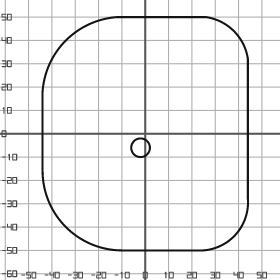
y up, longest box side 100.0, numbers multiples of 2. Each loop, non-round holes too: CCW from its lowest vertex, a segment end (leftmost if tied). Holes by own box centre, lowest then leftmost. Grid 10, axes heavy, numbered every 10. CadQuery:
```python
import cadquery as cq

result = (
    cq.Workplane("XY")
    .moveTo(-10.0, -50.0)
    .lineTo(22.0, -50.0)
    .threePointArc((38.0, -44.0), (44.0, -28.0))
    .lineTo(44.0, 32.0)
    .threePointArc((38.0, 44.0), (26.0, 50.0))
    .lineTo(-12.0, 50.0)
    .threePointArc((-34.0, 40.0), (-44.0, 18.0))
    .lineTo(-44.0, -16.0)
    .threePointArc((-34.0, -40.0), (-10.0, -50.0))
    .close()
    .moveTo(-2.0, -6.0)
    .circle(4.0)
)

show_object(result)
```